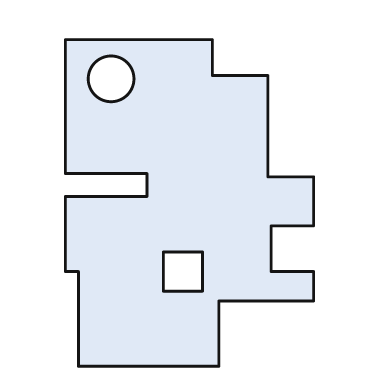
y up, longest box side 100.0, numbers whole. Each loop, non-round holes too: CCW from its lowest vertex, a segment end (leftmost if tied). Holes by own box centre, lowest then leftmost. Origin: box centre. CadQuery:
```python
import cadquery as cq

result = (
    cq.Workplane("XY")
    .moveTo(-34.0, -50.0)
    .lineTo(9.0, -50.0)
    .lineTo(9.0, -30.0)
    .lineTo(38.0, -30.0)
    .lineTo(38.0, -21.0)
    .lineTo(25.0, -21.0)
    .lineTo(25.0, -7.0)
    .lineTo(38.0, -7.0)
    .lineTo(38.0, 8.0)
    .lineTo(24.0, 8.0)
    .lineTo(24.0, 39.0)
    .lineTo(7.0, 39.0)
    .lineTo(7.0, 50.0)
    .lineTo(-38.0, 50.0)
    .lineTo(-38.0, 9.0)
    .lineTo(-13.0, 9.0)
    .lineTo(-13.0, 2.0)
    .lineTo(-38.0, 2.0)
    .lineTo(-38.0, -21.0)
    .lineTo(-34.0, -21.0)
    .close()
    .moveTo(-8.0, -27.0)
    .lineTo(4.0, -27.0)
    .lineTo(4.0, -15.0)
    .lineTo(-8.0, -15.0)
    .close()
    .moveTo(-24.0, 38.0)
    .circle(7.0)
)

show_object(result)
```